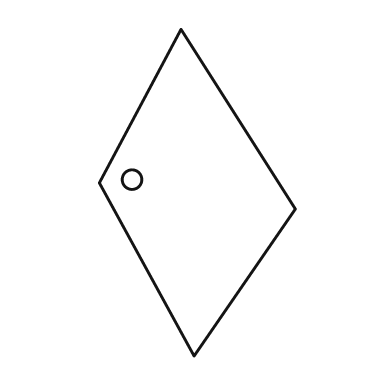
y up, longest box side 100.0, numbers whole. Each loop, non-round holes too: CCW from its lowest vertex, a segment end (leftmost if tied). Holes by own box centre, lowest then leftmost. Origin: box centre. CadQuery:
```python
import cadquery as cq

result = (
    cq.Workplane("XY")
    .moveTo(-1.0, -50.0)
    .lineTo(30.0, -5.0)
    .lineTo(-5.0, 50.0)
    .lineTo(-30.0, 3.0)
    .close()
    .moveTo(-20.0, 4.0)
    .circle(3.0)
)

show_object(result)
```